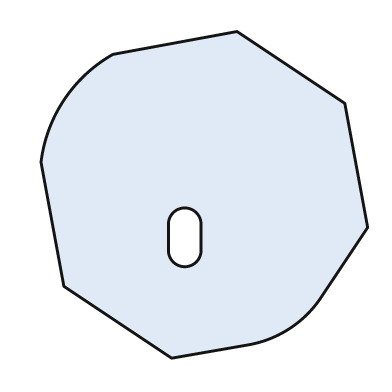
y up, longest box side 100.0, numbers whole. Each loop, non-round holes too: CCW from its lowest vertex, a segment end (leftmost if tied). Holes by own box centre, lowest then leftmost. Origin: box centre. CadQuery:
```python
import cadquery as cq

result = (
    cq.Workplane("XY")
    .moveTo(-10.0, -50.0)
    .lineTo(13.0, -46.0)
    .threePointArc((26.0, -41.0), (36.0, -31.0))
    .lineTo(50.0, -10.0)
    .lineTo(43.0, 28.0)
    .lineTo(10.0, 50.0)
    .lineTo(-28.0, 43.0)
    .threePointArc((-43.0, 29.0), (-50.0, 10.0))
    .lineTo(-43.0, -28.0)
    .close()
    .moveTo(-11.0, -17.0)
    .threePointArc((-6.0, -22.0), (-1.0, -17.0))
    .lineTo(-1.0, -9.0)
    .threePointArc((-6.0, -4.0), (-11.0, -9.0))
    .close()
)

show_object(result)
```